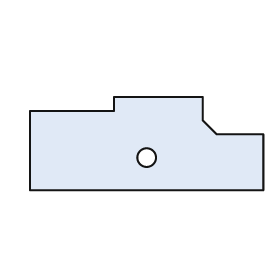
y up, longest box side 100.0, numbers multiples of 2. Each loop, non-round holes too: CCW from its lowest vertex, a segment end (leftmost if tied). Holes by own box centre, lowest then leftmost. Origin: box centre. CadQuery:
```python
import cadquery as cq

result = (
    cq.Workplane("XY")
    .moveTo(-50.0, -20.0)
    .lineTo(50.0, -20.0)
    .lineTo(50.0, 4.0)
    .lineTo(30.0, 4.0)
    .lineTo(24.0, 10.0)
    .lineTo(24.0, 20.0)
    .lineTo(-14.0, 20.0)
    .lineTo(-14.0, 14.0)
    .lineTo(-50.0, 14.0)
    .close()
    .moveTo(0.0, -6.0)
    .circle(4.0)
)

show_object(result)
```